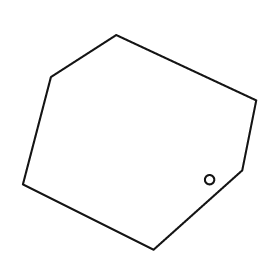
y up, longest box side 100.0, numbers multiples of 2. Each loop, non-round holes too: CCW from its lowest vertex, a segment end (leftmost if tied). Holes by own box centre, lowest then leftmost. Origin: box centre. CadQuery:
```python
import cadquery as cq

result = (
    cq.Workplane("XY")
    .moveTo(6.0, -46.0)
    .lineTo(44.0, -12.0)
    .lineTo(50.0, 18.0)
    .lineTo(-10.0, 46.0)
    .lineTo(-38.0, 28.0)
    .lineTo(-50.0, -18.0)
    .close()
    .moveTo(30.0, -16.0)
    .circle(2.0)
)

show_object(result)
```